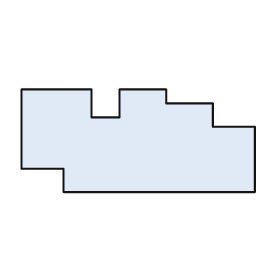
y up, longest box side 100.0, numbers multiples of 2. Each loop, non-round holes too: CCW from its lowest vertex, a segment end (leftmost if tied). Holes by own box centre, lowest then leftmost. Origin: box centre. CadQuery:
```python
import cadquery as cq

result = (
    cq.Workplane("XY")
    .moveTo(-32.0, -22.0)
    .lineTo(50.0, -22.0)
    .lineTo(50.0, 6.0)
    .lineTo(32.0, 6.0)
    .lineTo(32.0, 16.0)
    .lineTo(12.0, 16.0)
    .lineTo(12.0, 22.0)
    .lineTo(-8.0, 22.0)
    .lineTo(-8.0, 10.0)
    .lineTo(-20.0, 10.0)
    .lineTo(-20.0, 22.0)
    .lineTo(-50.0, 22.0)
    .lineTo(-50.0, -12.0)
    .lineTo(-32.0, -12.0)
    .close()
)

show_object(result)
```